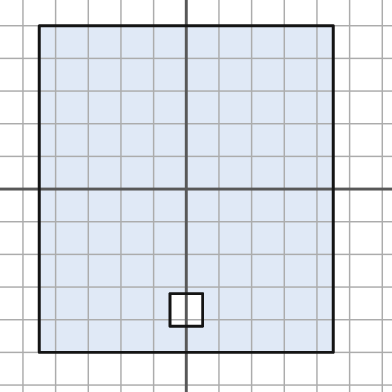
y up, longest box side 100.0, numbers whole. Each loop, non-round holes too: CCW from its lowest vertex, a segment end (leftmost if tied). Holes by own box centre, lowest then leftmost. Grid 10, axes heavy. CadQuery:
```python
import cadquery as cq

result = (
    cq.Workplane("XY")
    .moveTo(-45.0, -50.0)
    .lineTo(45.0, -50.0)
    .lineTo(45.0, 50.0)
    .lineTo(-45.0, 50.0)
    .close()
    .moveTo(-5.0, -42.0)
    .lineTo(5.0, -42.0)
    .lineTo(5.0, -32.0)
    .lineTo(-5.0, -32.0)
    .close()
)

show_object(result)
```